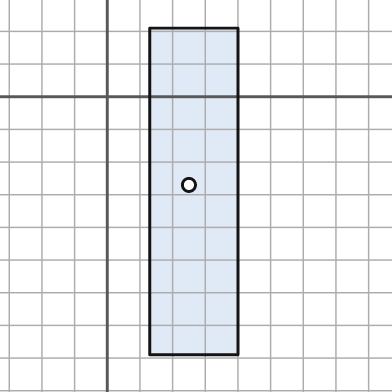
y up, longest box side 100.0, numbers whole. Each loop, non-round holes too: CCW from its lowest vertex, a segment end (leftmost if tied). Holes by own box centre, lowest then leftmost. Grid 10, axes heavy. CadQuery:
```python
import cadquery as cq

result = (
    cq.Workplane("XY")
    .moveTo(13.0, -79.0)
    .lineTo(40.0, -79.0)
    .lineTo(40.0, 21.0)
    .lineTo(13.0, 21.0)
    .close()
    .moveTo(25.0, -27.0)
    .circle(2.0)
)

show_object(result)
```